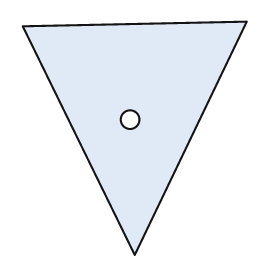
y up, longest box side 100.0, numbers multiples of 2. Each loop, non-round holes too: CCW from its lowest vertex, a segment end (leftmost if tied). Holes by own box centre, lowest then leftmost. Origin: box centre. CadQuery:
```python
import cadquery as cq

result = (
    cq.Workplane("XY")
    .moveTo(0.0, -50.0)
    .lineTo(48.0, 50.0)
    .lineTo(-48.0, 48.0)
    .close()
    .moveTo(-2.0, 8.0)
    .circle(4.0)
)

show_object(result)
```